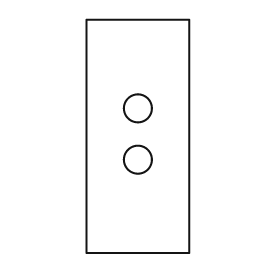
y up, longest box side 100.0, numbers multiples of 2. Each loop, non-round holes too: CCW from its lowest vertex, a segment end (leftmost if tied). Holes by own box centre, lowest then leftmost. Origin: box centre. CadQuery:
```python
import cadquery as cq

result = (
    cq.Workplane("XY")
    .moveTo(-22.0, -50.0)
    .lineTo(22.0, -50.0)
    .lineTo(22.0, 50.0)
    .lineTo(-22.0, 50.0)
    .close()
    .moveTo(0.0, -10.0)
    .circle(6.0)
    .moveTo(0.0, 12.0)
    .circle(6.0)
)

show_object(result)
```